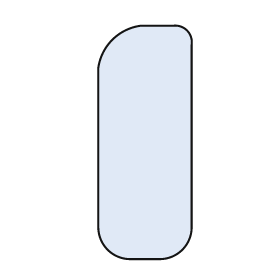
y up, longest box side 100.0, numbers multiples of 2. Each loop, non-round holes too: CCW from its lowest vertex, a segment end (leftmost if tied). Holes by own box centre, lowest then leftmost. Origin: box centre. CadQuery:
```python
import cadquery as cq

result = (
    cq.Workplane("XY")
    .moveTo(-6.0, -50.0)
    .lineTo(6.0, -50.0)
    .threePointArc((16.0, -46.0), (20.0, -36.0))
    .lineTo(20.0, 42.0)
    .threePointArc((18.0, 48.0), (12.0, 50.0))
    .lineTo(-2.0, 50.0)
    .threePointArc((-14.0, 44.0), (-20.0, 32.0))
    .lineTo(-20.0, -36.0)
    .threePointArc((-16.0, -46.0), (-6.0, -50.0))
    .close()
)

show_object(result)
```